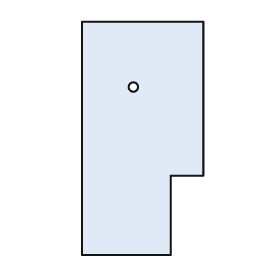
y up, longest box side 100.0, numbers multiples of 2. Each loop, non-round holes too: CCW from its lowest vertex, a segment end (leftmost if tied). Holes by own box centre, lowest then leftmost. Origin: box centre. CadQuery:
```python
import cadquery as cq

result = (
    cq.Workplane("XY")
    .moveTo(-26.0, -50.0)
    .lineTo(12.0, -50.0)
    .lineTo(12.0, -16.0)
    .lineTo(26.0, -16.0)
    .lineTo(26.0, 50.0)
    .lineTo(-26.0, 50.0)
    .close()
    .moveTo(-4.0, 22.0)
    .circle(2.0)
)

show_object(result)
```